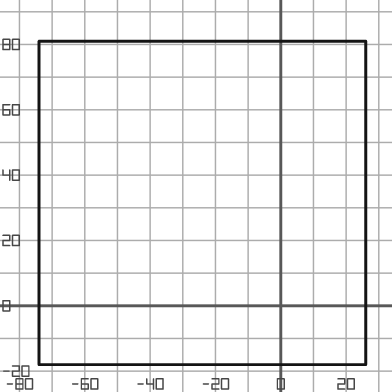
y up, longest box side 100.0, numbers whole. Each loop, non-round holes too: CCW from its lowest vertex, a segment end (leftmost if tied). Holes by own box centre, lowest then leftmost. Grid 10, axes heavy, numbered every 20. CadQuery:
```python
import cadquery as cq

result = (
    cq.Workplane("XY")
    .moveTo(-74.0, -18.0)
    .lineTo(26.0, -18.0)
    .lineTo(26.0, 81.0)
    .lineTo(-74.0, 81.0)
    .close()
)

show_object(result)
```